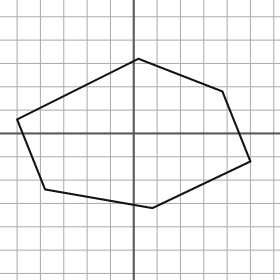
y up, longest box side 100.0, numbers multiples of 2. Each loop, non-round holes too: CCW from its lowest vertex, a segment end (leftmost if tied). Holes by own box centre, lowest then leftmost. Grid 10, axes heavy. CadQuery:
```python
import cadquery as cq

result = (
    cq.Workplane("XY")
    .moveTo(8.0, -32.0)
    .lineTo(50.0, -12.0)
    .lineTo(38.0, 18.0)
    .lineTo(2.0, 32.0)
    .lineTo(-50.0, 6.0)
    .lineTo(-38.0, -24.0)
    .close()
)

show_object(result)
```